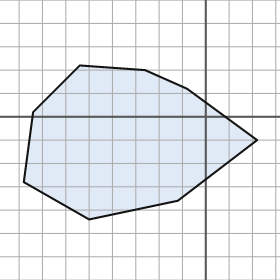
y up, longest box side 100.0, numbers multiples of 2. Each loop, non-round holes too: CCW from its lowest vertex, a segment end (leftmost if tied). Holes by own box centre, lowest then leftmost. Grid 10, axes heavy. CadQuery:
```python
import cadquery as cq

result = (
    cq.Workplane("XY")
    .moveTo(-50.0, -44.0)
    .lineTo(-12.0, -36.0)
    .lineTo(22.0, -10.0)
    .lineTo(-8.0, 12.0)
    .lineTo(-26.0, 20.0)
    .lineTo(-54.0, 22.0)
    .lineTo(-74.0, 2.0)
    .lineTo(-78.0, -28.0)
    .close()
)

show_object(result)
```